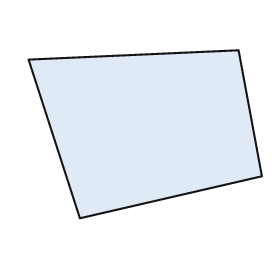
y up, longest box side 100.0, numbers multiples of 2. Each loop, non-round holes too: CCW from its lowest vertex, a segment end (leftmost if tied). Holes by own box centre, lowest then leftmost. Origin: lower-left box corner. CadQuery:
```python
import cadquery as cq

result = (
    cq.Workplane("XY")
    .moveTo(22.0, 0.0)
    .lineTo(100.0, 18.0)
    .lineTo(90.0, 72.0)
    .lineTo(0.0, 68.0)
    .close()
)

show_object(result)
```